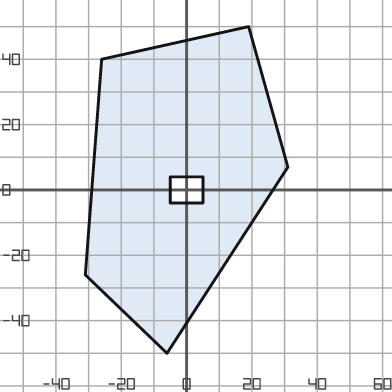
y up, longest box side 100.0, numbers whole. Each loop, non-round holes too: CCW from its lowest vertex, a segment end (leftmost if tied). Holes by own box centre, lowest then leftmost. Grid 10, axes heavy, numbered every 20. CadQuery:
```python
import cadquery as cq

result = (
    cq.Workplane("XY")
    .moveTo(-6.0, -50.0)
    .lineTo(31.0, 7.0)
    .lineTo(19.0, 50.0)
    .lineTo(-26.0, 40.0)
    .lineTo(-31.0, -26.0)
    .close()
    .moveTo(-5.0, -4.0)
    .lineTo(5.0, -4.0)
    .lineTo(5.0, 4.0)
    .lineTo(-5.0, 4.0)
    .close()
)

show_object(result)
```